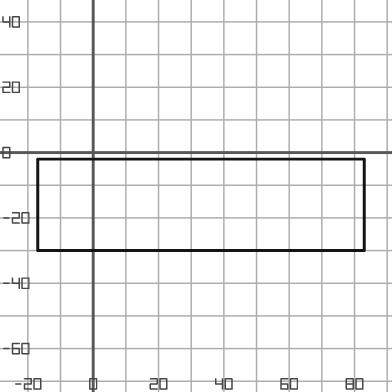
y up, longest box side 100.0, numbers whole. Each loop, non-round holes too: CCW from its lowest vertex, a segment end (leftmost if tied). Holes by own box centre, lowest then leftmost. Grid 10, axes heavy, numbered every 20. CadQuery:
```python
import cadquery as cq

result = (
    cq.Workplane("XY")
    .moveTo(-17.0, -30.0)
    .lineTo(83.0, -30.0)
    .lineTo(83.0, -2.0)
    .lineTo(-17.0, -2.0)
    .close()
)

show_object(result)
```